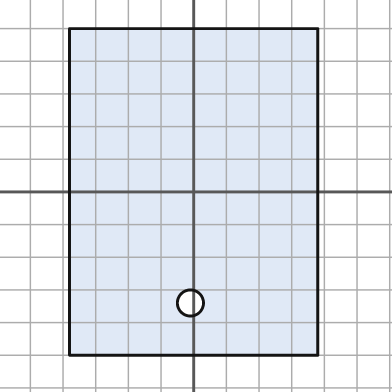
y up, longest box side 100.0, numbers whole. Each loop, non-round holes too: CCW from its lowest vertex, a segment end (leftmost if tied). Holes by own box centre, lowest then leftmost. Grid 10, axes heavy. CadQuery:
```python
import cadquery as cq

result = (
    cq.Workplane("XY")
    .moveTo(-38.0, -50.0)
    .lineTo(38.0, -50.0)
    .lineTo(38.0, 50.0)
    .lineTo(-38.0, 50.0)
    .close()
    .moveTo(-1.0, -34.0)
    .circle(4.0)
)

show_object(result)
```